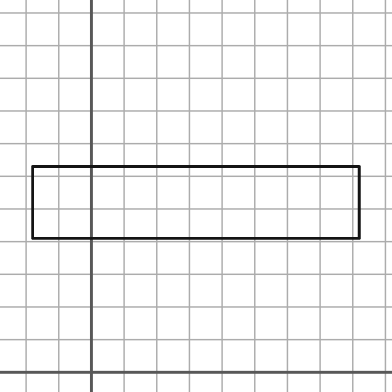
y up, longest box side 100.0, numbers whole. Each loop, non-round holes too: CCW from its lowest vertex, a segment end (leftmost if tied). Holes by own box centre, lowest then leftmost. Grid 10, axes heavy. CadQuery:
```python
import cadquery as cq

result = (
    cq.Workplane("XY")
    .moveTo(-18.0, 41.0)
    .lineTo(82.0, 41.0)
    .lineTo(82.0, 63.0)
    .lineTo(-18.0, 63.0)
    .close()
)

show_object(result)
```